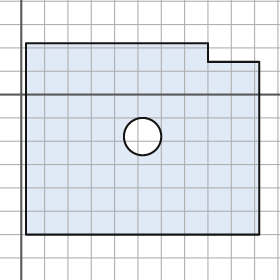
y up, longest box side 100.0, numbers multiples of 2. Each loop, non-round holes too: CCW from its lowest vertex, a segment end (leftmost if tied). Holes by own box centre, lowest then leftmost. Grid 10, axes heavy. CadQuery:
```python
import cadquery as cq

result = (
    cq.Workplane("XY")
    .moveTo(2.0, -60.0)
    .lineTo(102.0, -60.0)
    .lineTo(102.0, 14.0)
    .lineTo(80.0, 14.0)
    .lineTo(80.0, 22.0)
    .lineTo(2.0, 22.0)
    .close()
    .moveTo(52.0, -18.0)
    .circle(8.0)
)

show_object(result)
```